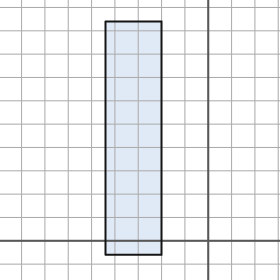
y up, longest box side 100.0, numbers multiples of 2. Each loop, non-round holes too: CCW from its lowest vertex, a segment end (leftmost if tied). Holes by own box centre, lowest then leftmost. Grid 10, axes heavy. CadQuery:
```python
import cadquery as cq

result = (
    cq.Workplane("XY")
    .moveTo(-44.0, -6.0)
    .lineTo(-20.0, -6.0)
    .lineTo(-20.0, 94.0)
    .lineTo(-44.0, 94.0)
    .close()
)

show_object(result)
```